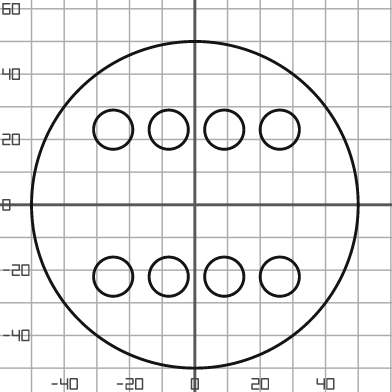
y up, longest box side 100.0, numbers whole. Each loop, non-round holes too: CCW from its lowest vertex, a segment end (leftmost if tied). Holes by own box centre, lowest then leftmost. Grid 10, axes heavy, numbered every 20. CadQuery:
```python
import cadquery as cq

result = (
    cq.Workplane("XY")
    .moveTo(0.0, 0.0)
    .circle(50.0)
    .moveTo(-25.0, -22.0)
    .circle(6.0)
    .moveTo(-8.0, -22.0)
    .circle(6.0)
    .moveTo(9.0, -22.0)
    .circle(6.0)
    .moveTo(26.0, -22.0)
    .circle(6.0)
    .moveTo(-25.0, 23.0)
    .circle(6.0)
    .moveTo(-8.0, 23.0)
    .circle(6.0)
    .moveTo(9.0, 23.0)
    .circle(6.0)
    .moveTo(26.0, 23.0)
    .circle(6.0)
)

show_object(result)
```